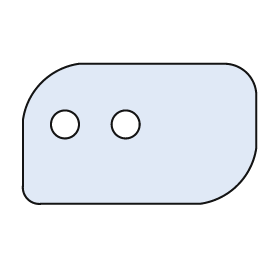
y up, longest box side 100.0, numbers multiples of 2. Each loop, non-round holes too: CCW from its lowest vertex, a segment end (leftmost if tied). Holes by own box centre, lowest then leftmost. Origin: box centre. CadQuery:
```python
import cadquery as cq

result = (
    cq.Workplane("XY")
    .moveTo(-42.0, -30.0)
    .lineTo(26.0, -30.0)
    .threePointArc((42.0, -22.0), (50.0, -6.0))
    .lineTo(50.0, 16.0)
    .threePointArc((46.0, 26.0), (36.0, 30.0))
    .lineTo(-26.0, 30.0)
    .threePointArc((-42.0, 22.0), (-50.0, 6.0))
    .lineTo(-50.0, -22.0)
    .threePointArc((-48.0, -28.0), (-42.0, -30.0))
    .close()
    .moveTo(-32.0, 4.0)
    .circle(6.0)
    .moveTo(-6.0, 4.0)
    .circle(6.0)
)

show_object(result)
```